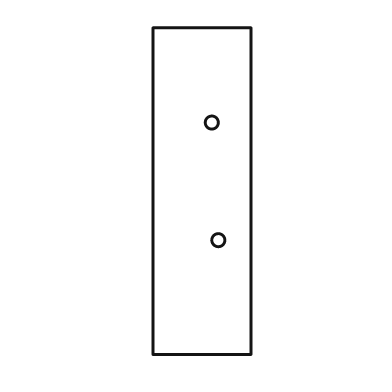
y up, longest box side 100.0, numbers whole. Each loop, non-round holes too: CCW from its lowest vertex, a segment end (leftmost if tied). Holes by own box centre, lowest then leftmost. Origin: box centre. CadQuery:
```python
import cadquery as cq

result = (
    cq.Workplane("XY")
    .moveTo(-15.0, -50.0)
    .lineTo(15.0, -50.0)
    .lineTo(15.0, 50.0)
    .lineTo(-15.0, 50.0)
    .close()
    .moveTo(5.0, -15.0)
    .circle(2.0)
    .moveTo(3.0, 21.0)
    .circle(2.0)
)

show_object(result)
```